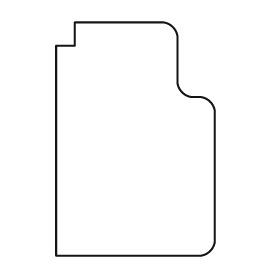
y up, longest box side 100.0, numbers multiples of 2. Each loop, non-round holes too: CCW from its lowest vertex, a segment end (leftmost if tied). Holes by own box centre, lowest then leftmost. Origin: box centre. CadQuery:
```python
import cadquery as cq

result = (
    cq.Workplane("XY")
    .moveTo(-34.0, -50.0)
    .lineTo(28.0, -50.0)
    .threePointArc((32.0, -48.0), (34.0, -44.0))
    .lineTo(34.0, 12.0)
    .threePointArc((32.0, 16.0), (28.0, 18.0))
    .lineTo(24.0, 18.0)
    .threePointArc((20.0, 20.0), (18.0, 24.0))
    .lineTo(18.0, 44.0)
    .threePointArc((16.0, 48.0), (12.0, 50.0))
    .lineTo(-26.0, 50.0)
    .lineTo(-26.0, 40.0)
    .lineTo(-34.0, 40.0)
    .close()
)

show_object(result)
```